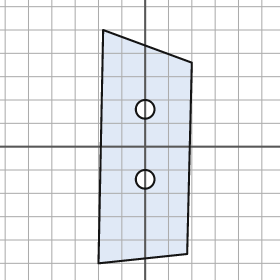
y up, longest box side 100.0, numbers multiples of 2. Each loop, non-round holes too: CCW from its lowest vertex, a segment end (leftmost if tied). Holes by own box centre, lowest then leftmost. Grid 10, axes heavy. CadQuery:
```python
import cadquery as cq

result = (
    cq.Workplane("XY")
    .moveTo(-20.0, -50.0)
    .lineTo(18.0, -46.0)
    .lineTo(20.0, 36.0)
    .lineTo(-18.0, 50.0)
    .close()
    .moveTo(0.0, -14.0)
    .circle(4.0)
    .moveTo(0.0, 16.0)
    .circle(4.0)
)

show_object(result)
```